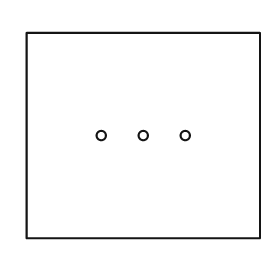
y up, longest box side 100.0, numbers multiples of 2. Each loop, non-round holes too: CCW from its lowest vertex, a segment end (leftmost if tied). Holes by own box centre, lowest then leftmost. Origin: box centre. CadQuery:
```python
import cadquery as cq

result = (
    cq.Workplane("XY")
    .moveTo(-50.0, -44.0)
    .lineTo(50.0, -44.0)
    .lineTo(50.0, 44.0)
    .lineTo(-50.0, 44.0)
    .close()
    .moveTo(-18.0, 0.0)
    .circle(2.0)
    .moveTo(0.0, 0.0)
    .circle(2.0)
    .moveTo(18.0, 0.0)
    .circle(2.0)
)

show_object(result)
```